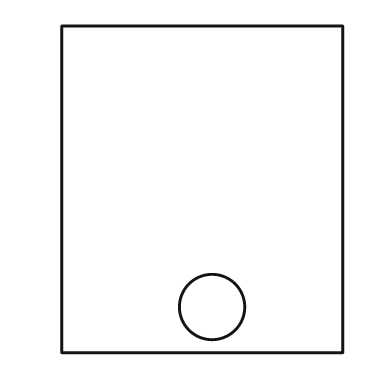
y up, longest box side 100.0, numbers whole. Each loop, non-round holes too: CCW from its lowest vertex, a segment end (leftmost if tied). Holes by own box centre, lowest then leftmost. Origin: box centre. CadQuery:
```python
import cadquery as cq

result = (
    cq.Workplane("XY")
    .moveTo(-43.0, -50.0)
    .lineTo(43.0, -50.0)
    .lineTo(43.0, 50.0)
    .lineTo(-43.0, 50.0)
    .close()
    .moveTo(3.0, -36.0)
    .circle(10.0)
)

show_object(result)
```